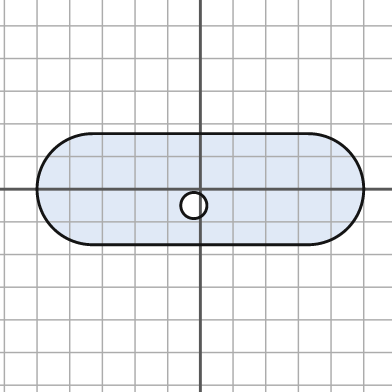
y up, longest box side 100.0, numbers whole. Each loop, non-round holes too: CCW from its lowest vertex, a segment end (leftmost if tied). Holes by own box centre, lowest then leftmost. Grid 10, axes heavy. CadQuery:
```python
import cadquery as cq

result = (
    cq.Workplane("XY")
    .moveTo(-33.0, -17.0)
    .lineTo(33.0, -17.0)
    .threePointArc((50.0, 0.0), (33.0, 17.0))
    .lineTo(-33.0, 17.0)
    .threePointArc((-50.0, 0.0), (-33.0, -17.0))
    .close()
    .moveTo(-2.0, -5.0)
    .circle(4.0)
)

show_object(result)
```